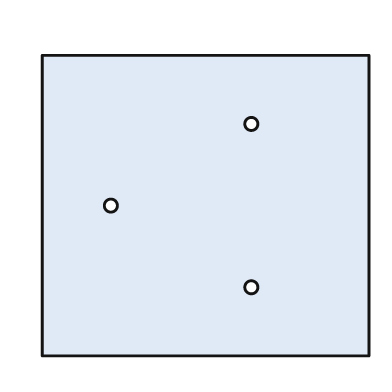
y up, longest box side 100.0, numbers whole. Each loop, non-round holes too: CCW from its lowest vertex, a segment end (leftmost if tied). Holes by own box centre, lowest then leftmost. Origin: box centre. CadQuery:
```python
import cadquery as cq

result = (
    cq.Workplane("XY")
    .moveTo(-50.0, -46.0)
    .lineTo(50.0, -46.0)
    .lineTo(50.0, 46.0)
    .lineTo(-50.0, 46.0)
    .close()
    .moveTo(14.0, -25.0)
    .circle(2.0)
    .moveTo(-29.0, 0.0)
    .circle(2.0)
    .moveTo(14.0, 25.0)
    .circle(2.0)
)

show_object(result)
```